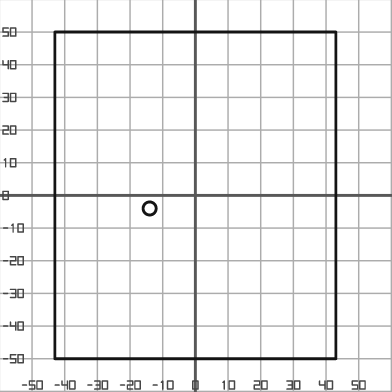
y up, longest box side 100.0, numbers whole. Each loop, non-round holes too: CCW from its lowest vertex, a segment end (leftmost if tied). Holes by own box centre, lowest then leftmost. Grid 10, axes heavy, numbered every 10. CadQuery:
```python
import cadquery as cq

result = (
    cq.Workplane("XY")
    .moveTo(-43.0, -50.0)
    .lineTo(43.0, -50.0)
    .lineTo(43.0, 50.0)
    .lineTo(-43.0, 50.0)
    .close()
    .moveTo(-14.0, -4.0)
    .circle(2.0)
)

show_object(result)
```